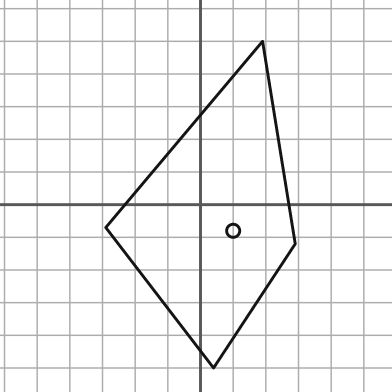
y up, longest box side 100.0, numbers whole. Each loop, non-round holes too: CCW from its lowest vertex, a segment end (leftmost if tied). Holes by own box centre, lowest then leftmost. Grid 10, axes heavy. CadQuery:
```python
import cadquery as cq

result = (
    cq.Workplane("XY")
    .moveTo(4.0, -50.0)
    .lineTo(29.0, -12.0)
    .lineTo(19.0, 50.0)
    .lineTo(-29.0, -7.0)
    .close()
    .moveTo(10.0, -8.0)
    .circle(2.0)
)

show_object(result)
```